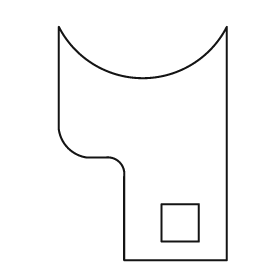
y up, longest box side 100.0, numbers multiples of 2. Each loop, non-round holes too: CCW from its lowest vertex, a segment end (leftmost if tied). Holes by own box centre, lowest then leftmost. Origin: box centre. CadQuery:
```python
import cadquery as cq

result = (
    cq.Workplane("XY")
    .moveTo(-8.0, -50.0)
    .lineTo(36.0, -50.0)
    .lineTo(36.0, 50.0)
    .threePointArc((0.0, 28.0), (-36.0, 50.0))
    .lineTo(-36.0, 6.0)
    .threePointArc((-32.0, -2.0), (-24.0, -6.0))
    .lineTo(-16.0, -6.0)
    .threePointArc((-10.0, -8.0), (-8.0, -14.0))
    .close()
    .moveTo(8.0, -42.0)
    .lineTo(24.0, -42.0)
    .lineTo(24.0, -26.0)
    .lineTo(8.0, -26.0)
    .close()
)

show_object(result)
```